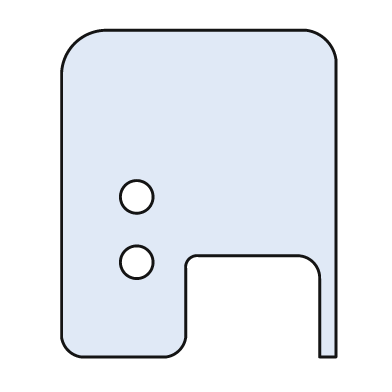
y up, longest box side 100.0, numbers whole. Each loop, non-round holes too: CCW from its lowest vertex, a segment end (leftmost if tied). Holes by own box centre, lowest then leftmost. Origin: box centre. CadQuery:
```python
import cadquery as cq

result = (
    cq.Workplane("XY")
    .moveTo(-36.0, -50.0)
    .lineTo(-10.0, -50.0)
    .threePointArc((-6.0, -48.0), (-4.0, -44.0))
    .lineTo(-4.0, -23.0)
    .threePointArc((-3.0, -20.0), (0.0, -19.0))
    .lineTo(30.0, -19.0)
    .threePointArc((35.0, -21.0), (37.0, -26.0))
    .lineTo(37.0, -50.0)
    .lineTo(42.0, -50.0)
    .lineTo(42.0, 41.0)
    .threePointArc((39.0, 47.0), (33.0, 50.0))
    .lineTo(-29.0, 50.0)
    .threePointArc((-38.0, 46.0), (-42.0, 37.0))
    .lineTo(-42.0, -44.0)
    .threePointArc((-40.0, -48.0), (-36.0, -50.0))
    .close()
    .moveTo(-19.0, -21.0)
    .circle(5.0)
    .moveTo(-19.0, -1.0)
    .circle(5.0)
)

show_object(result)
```